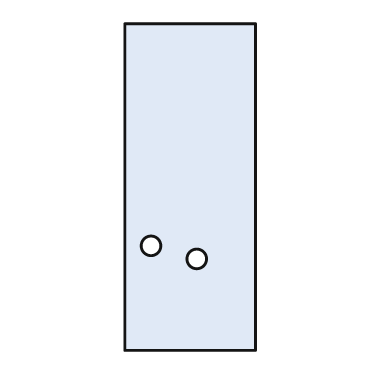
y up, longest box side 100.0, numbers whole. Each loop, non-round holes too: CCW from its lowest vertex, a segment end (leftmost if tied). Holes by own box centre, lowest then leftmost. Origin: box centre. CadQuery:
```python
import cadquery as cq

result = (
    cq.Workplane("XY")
    .moveTo(-20.0, -50.0)
    .lineTo(20.0, -50.0)
    .lineTo(20.0, 50.0)
    .lineTo(-20.0, 50.0)
    .close()
    .moveTo(2.0, -22.0)
    .circle(3.0)
    .moveTo(-12.0, -18.0)
    .circle(3.0)
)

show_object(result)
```